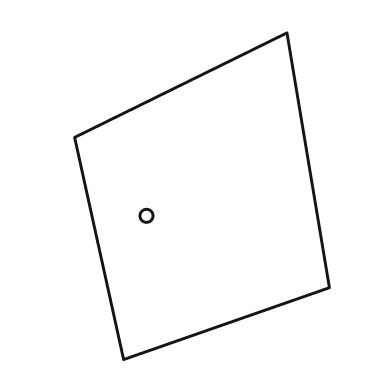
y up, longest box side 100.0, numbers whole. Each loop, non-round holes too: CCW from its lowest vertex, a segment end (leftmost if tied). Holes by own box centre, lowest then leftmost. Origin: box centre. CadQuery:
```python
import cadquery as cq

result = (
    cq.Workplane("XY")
    .moveTo(-24.0, -50.0)
    .lineTo(39.0, -28.0)
    .lineTo(26.0, 50.0)
    .lineTo(-39.0, 18.0)
    .close()
    .moveTo(-17.0, -6.0)
    .circle(2.0)
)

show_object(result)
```